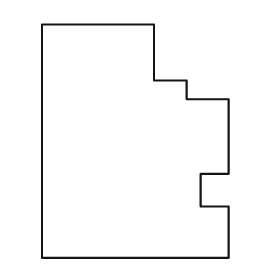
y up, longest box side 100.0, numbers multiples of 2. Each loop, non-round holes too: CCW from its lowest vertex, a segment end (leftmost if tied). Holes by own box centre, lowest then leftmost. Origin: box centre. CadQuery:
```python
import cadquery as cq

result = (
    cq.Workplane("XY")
    .moveTo(-40.0, -50.0)
    .lineTo(40.0, -50.0)
    .lineTo(40.0, -28.0)
    .lineTo(28.0, -28.0)
    .lineTo(28.0, -14.0)
    .lineTo(40.0, -14.0)
    .lineTo(40.0, 18.0)
    .lineTo(22.0, 18.0)
    .lineTo(22.0, 26.0)
    .lineTo(8.0, 26.0)
    .lineTo(8.0, 50.0)
    .lineTo(-40.0, 50.0)
    .close()
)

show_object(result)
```